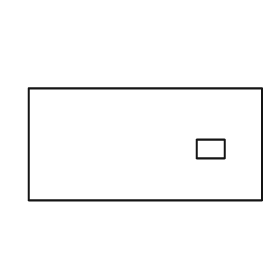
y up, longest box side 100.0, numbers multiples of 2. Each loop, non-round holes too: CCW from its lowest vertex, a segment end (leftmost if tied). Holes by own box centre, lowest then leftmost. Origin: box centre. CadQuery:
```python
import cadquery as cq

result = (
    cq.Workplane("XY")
    .moveTo(-50.0, -24.0)
    .lineTo(50.0, -24.0)
    .lineTo(50.0, 24.0)
    .lineTo(-50.0, 24.0)
    .close()
    .moveTo(22.0, -6.0)
    .lineTo(34.0, -6.0)
    .lineTo(34.0, 2.0)
    .lineTo(22.0, 2.0)
    .close()
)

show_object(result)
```